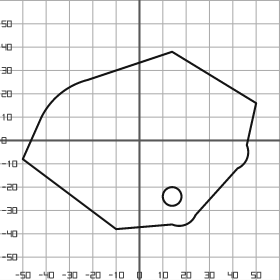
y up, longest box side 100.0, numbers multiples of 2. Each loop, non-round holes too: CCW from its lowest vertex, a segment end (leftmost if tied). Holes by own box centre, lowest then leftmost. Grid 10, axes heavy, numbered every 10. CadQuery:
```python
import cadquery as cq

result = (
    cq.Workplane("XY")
    .moveTo(-10.0, -38.0)
    .lineTo(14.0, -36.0)
    .threePointArc((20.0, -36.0), (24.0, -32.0))
    .lineTo(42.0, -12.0)
    .threePointArc((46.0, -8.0), (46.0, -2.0))
    .lineTo(50.0, 16.0)
    .lineTo(14.0, 38.0)
    .lineTo(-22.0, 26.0)
    .threePointArc((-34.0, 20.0), (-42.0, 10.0))
    .lineTo(-50.0, -8.0)
    .close()
    .moveTo(14.0, -24.0)
    .circle(4.0)
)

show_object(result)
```